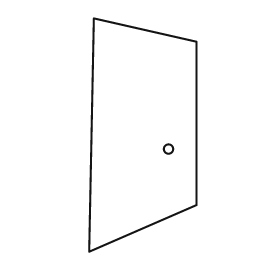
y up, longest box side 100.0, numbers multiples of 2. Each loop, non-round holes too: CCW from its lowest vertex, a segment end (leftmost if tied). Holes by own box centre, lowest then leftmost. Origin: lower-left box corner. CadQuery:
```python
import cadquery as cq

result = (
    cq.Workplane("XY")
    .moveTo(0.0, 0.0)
    .lineTo(46.0, 20.0)
    .lineTo(46.0, 90.0)
    .lineTo(2.0, 100.0)
    .close()
    .moveTo(34.0, 44.0)
    .circle(2.0)
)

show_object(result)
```